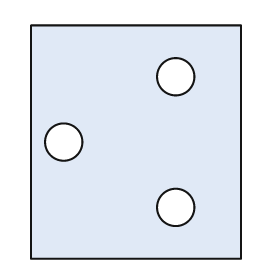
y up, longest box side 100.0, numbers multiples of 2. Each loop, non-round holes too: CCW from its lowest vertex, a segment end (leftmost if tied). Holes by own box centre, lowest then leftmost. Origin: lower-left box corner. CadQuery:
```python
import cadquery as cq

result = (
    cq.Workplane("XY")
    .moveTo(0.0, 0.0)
    .lineTo(90.0, 0.0)
    .lineTo(90.0, 100.0)
    .lineTo(0.0, 100.0)
    .close()
    .moveTo(62.0, 22.0)
    .circle(8.0)
    .moveTo(14.0, 50.0)
    .circle(8.0)
    .moveTo(62.0, 78.0)
    .circle(8.0)
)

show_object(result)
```